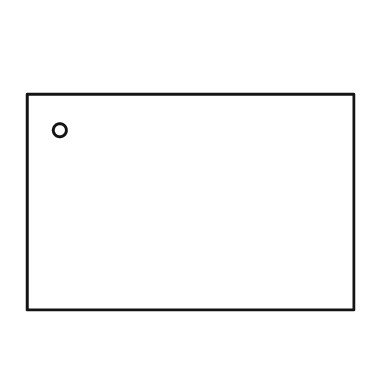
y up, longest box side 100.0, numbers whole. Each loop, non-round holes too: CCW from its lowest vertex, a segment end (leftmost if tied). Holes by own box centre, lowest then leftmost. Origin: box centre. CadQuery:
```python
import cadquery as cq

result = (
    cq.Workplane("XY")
    .moveTo(-50.0, -33.0)
    .lineTo(50.0, -33.0)
    .lineTo(50.0, 33.0)
    .lineTo(-50.0, 33.0)
    .close()
    .moveTo(-40.0, 22.0)
    .circle(2.0)
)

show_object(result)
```